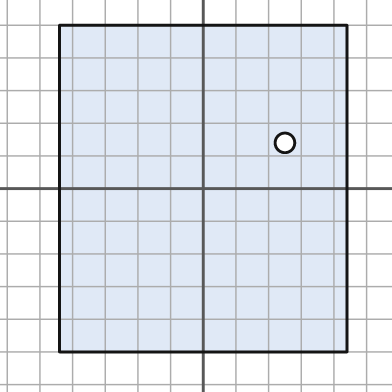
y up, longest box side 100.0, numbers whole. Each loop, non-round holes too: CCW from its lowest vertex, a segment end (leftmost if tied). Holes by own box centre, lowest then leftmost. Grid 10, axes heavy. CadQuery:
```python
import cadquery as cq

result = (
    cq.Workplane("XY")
    .moveTo(-44.0, -50.0)
    .lineTo(44.0, -50.0)
    .lineTo(44.0, 50.0)
    .lineTo(-44.0, 50.0)
    .close()
    .moveTo(25.0, 14.0)
    .circle(3.0)
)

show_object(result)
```